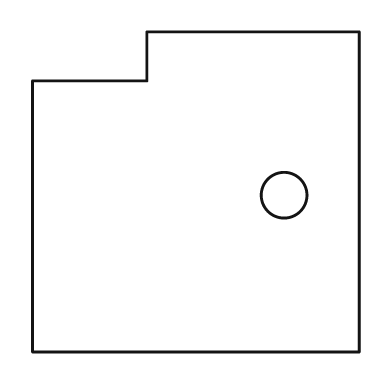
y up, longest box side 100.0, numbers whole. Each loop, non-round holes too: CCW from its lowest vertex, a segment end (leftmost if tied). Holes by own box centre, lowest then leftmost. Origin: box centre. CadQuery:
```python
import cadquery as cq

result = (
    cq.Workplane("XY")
    .moveTo(-50.0, -49.0)
    .lineTo(50.0, -49.0)
    .lineTo(50.0, 49.0)
    .lineTo(-15.0, 49.0)
    .lineTo(-15.0, 34.0)
    .lineTo(-50.0, 34.0)
    .close()
    .moveTo(27.0, -1.0)
    .circle(7.0)
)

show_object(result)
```